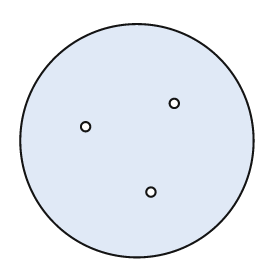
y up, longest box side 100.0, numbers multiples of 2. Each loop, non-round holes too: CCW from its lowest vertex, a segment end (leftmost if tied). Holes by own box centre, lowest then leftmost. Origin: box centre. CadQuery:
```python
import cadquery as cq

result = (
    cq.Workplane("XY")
    .moveTo(0.0, 0.0)
    .circle(50.0)
    .moveTo(6.0, -22.0)
    .circle(2.0)
    .moveTo(-22.0, 6.0)
    .circle(2.0)
    .moveTo(16.0, 16.0)
    .circle(2.0)
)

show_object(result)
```